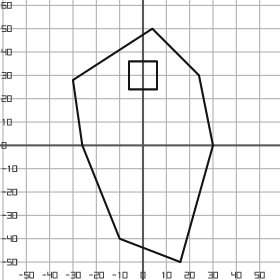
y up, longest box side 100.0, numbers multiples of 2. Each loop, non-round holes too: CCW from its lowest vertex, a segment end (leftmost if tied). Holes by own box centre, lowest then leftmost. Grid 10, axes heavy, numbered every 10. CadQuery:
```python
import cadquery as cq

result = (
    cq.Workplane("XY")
    .moveTo(16.0, -50.0)
    .lineTo(30.0, 0.0)
    .lineTo(24.0, 30.0)
    .lineTo(4.0, 50.0)
    .lineTo(-30.0, 28.0)
    .lineTo(-26.0, 0.0)
    .lineTo(-10.0, -40.0)
    .close()
    .moveTo(-6.0, 24.0)
    .lineTo(6.0, 24.0)
    .lineTo(6.0, 36.0)
    .lineTo(-6.0, 36.0)
    .close()
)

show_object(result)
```